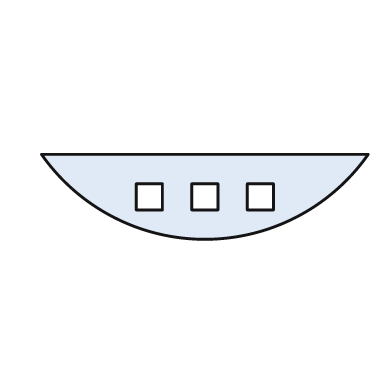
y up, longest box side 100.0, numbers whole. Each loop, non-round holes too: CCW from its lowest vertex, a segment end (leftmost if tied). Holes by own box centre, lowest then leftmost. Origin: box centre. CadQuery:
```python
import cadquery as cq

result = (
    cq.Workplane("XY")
    .moveTo(-50.0, 13.0)
    .threePointArc((0.0, -13.0), (50.0, 13.0))
    .close()
    .moveTo(-21.0, -4.0)
    .lineTo(-13.0, -4.0)
    .lineTo(-13.0, 4.0)
    .lineTo(-21.0, 4.0)
    .close()
    .moveTo(-4.0, -4.0)
    .lineTo(4.0, -4.0)
    .lineTo(4.0, 4.0)
    .lineTo(-4.0, 4.0)
    .close()
    .moveTo(13.0, -4.0)
    .lineTo(21.0, -4.0)
    .lineTo(21.0, 4.0)
    .lineTo(13.0, 4.0)
    .close()
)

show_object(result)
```